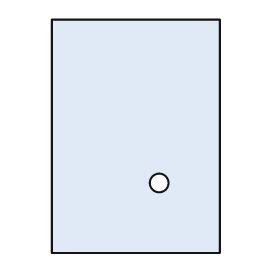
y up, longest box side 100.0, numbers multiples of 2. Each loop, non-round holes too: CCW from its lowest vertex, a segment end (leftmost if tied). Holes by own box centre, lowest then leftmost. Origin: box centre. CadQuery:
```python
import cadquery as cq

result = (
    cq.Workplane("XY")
    .moveTo(-36.0, -50.0)
    .lineTo(36.0, -50.0)
    .lineTo(36.0, 50.0)
    .lineTo(-36.0, 50.0)
    .close()
    .moveTo(10.0, -20.0)
    .circle(4.0)
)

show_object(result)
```